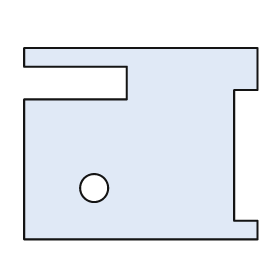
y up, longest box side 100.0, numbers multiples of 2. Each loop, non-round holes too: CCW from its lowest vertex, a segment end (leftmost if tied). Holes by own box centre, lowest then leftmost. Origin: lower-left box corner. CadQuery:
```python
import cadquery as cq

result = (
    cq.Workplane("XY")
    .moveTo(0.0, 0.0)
    .lineTo(100.0, 0.0)
    .lineTo(100.0, 8.0)
    .lineTo(90.0, 8.0)
    .lineTo(90.0, 64.0)
    .lineTo(100.0, 64.0)
    .lineTo(100.0, 82.0)
    .lineTo(0.0, 82.0)
    .lineTo(0.0, 74.0)
    .lineTo(44.0, 74.0)
    .lineTo(44.0, 60.0)
    .lineTo(0.0, 60.0)
    .close()
    .moveTo(30.0, 22.0)
    .circle(6.0)
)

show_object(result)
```